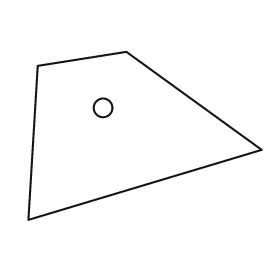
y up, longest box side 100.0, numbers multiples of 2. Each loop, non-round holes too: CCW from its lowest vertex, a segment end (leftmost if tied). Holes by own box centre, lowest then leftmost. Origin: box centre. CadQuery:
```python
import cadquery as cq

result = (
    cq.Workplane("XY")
    .moveTo(-50.0, -36.0)
    .lineTo(50.0, -6.0)
    .lineTo(-8.0, 36.0)
    .lineTo(-46.0, 30.0)
    .close()
    .moveTo(-18.0, 12.0)
    .circle(4.0)
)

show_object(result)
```